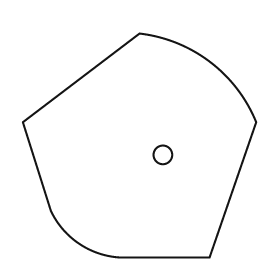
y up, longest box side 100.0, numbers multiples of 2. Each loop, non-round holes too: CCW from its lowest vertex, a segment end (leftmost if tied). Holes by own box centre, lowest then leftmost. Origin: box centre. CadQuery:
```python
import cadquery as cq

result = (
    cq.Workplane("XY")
    .moveTo(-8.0, -48.0)
    .lineTo(30.0, -48.0)
    .lineTo(50.0, 10.0)
    .threePointArc((30.0, 36.0), (0.0, 48.0))
    .lineTo(-50.0, 10.0)
    .lineTo(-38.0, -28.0)
    .threePointArc((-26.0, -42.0), (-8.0, -48.0))
    .close()
    .moveTo(10.0, -4.0)
    .circle(4.0)
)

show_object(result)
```